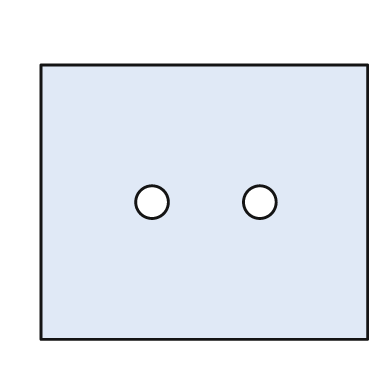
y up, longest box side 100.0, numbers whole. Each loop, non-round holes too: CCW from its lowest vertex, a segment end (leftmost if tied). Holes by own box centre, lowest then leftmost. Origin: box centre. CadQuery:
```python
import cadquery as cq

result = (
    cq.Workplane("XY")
    .moveTo(-50.0, -42.0)
    .lineTo(50.0, -42.0)
    .lineTo(50.0, 42.0)
    .lineTo(-50.0, 42.0)
    .close()
    .moveTo(-16.0, 0.0)
    .circle(5.0)
    .moveTo(17.0, 0.0)
    .circle(5.0)
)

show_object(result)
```